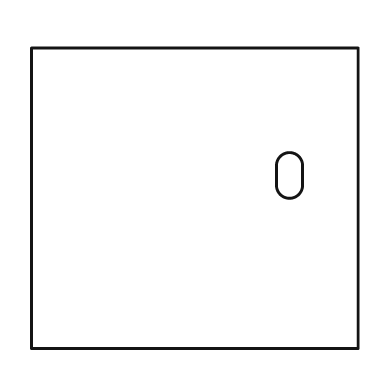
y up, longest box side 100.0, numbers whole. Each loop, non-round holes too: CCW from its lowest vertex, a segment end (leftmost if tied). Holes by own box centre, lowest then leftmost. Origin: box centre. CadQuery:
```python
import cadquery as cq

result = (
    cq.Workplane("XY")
    .moveTo(-50.0, -46.0)
    .lineTo(50.0, -46.0)
    .lineTo(50.0, 46.0)
    .lineTo(-50.0, 46.0)
    .close()
    .moveTo(25.0, 4.0)
    .threePointArc((29.0, 0.0), (33.0, 4.0))
    .lineTo(33.0, 10.0)
    .threePointArc((29.0, 14.0), (25.0, 10.0))
    .close()
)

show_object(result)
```